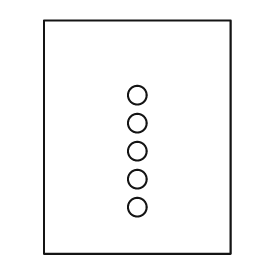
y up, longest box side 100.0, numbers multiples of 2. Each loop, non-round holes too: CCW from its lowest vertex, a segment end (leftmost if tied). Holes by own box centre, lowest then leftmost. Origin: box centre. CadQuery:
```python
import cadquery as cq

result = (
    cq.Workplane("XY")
    .moveTo(-40.0, -50.0)
    .lineTo(40.0, -50.0)
    .lineTo(40.0, 50.0)
    .lineTo(-40.0, 50.0)
    .close()
    .moveTo(0.0, -30.0)
    .circle(4.0)
    .moveTo(0.0, -18.0)
    .circle(4.0)
    .moveTo(0.0, -6.0)
    .circle(4.0)
    .moveTo(0.0, 6.0)
    .circle(4.0)
    .moveTo(0.0, 18.0)
    .circle(4.0)
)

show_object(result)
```